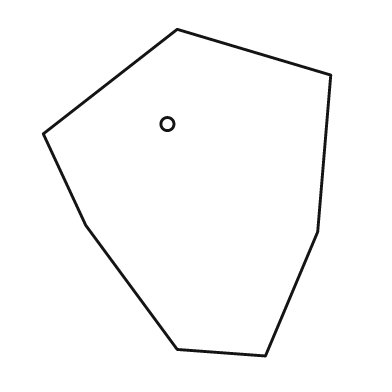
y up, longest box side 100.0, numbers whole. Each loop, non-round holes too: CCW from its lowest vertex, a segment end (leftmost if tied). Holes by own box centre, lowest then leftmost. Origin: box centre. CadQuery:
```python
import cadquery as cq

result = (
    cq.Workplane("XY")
    .moveTo(24.0, -50.0)
    .lineTo(40.0, -12.0)
    .lineTo(44.0, 36.0)
    .lineTo(-3.0, 50.0)
    .lineTo(-44.0, 18.0)
    .lineTo(-31.0, -10.0)
    .lineTo(-3.0, -48.0)
    .close()
    .moveTo(-6.0, 21.0)
    .circle(2.0)
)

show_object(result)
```